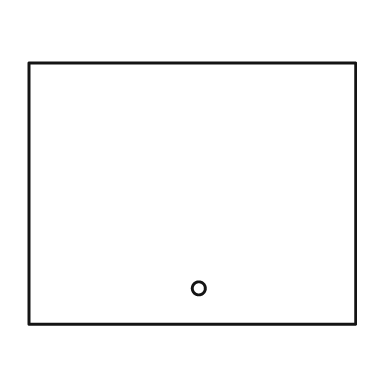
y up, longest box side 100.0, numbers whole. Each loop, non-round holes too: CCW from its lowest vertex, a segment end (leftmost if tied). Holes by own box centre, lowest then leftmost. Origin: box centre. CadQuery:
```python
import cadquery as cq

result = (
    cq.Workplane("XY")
    .moveTo(-50.0, -40.0)
    .lineTo(50.0, -40.0)
    .lineTo(50.0, 40.0)
    .lineTo(-50.0, 40.0)
    .close()
    .moveTo(2.0, -29.0)
    .circle(2.0)
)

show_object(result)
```